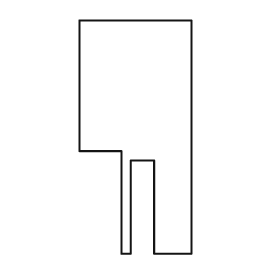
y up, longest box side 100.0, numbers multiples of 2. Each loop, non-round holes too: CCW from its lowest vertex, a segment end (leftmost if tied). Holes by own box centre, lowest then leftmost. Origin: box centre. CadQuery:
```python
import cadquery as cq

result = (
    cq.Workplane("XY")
    .moveTo(-6.0, -50.0)
    .lineTo(-2.0, -50.0)
    .lineTo(-2.0, -10.0)
    .lineTo(8.0, -10.0)
    .lineTo(8.0, -50.0)
    .lineTo(24.0, -50.0)
    .lineTo(24.0, 50.0)
    .lineTo(-24.0, 50.0)
    .lineTo(-24.0, -6.0)
    .lineTo(-6.0, -6.0)
    .close()
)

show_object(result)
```